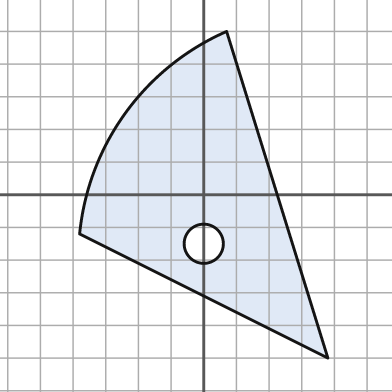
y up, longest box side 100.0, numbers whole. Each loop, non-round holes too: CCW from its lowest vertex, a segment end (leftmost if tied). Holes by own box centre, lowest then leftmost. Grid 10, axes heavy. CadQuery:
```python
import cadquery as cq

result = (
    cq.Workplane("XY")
    .moveTo(38.0, -50.0)
    .lineTo(7.0, 50.0)
    .threePointArc((-24.0, 25.0), (-38.0, -12.0))
    .close()
    .moveTo(0.0, -15.0)
    .circle(6.0)
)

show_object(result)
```